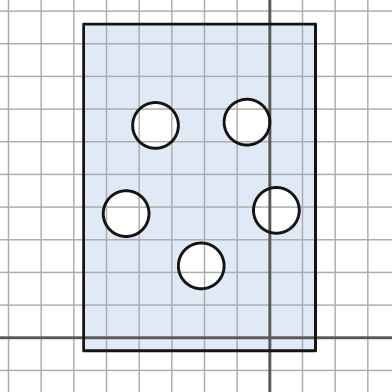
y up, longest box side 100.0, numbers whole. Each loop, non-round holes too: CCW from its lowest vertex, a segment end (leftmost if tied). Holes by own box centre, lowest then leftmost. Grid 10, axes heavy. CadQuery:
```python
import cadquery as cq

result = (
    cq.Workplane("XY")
    .moveTo(-57.0, -4.0)
    .lineTo(14.0, -4.0)
    .lineTo(14.0, 96.0)
    .lineTo(-57.0, 96.0)
    .close()
    .moveTo(-21.0, 22.0)
    .circle(7.0)
    .moveTo(-44.0, 38.0)
    .circle(7.0)
    .moveTo(2.0, 39.0)
    .circle(7.0)
    .moveTo(-35.0, 65.0)
    .circle(7.0)
    .moveTo(-7.0, 66.0)
    .circle(7.0)
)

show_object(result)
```